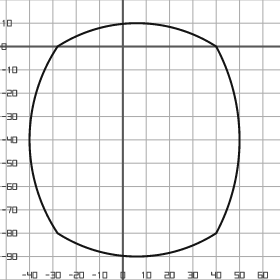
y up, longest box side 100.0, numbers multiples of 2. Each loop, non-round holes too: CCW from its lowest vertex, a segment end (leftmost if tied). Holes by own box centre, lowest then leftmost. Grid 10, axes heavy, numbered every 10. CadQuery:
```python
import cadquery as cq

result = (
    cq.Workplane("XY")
    .moveTo(-28.0, -80.0)
    .threePointArc((6.0, -90.0), (40.0, -80.0))
    .threePointArc((50.0, -40.0), (40.0, 0.0))
    .threePointArc((6.0, 10.0), (-28.0, 0.0))
    .threePointArc((-40.0, -40.0), (-28.0, -80.0))
    .close()
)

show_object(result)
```